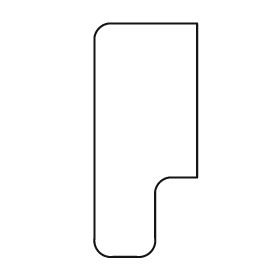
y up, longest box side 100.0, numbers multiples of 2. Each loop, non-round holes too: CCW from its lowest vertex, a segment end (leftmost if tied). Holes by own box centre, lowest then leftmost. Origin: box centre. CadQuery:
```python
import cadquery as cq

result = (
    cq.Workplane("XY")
    .moveTo(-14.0, -50.0)
    .lineTo(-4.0, -50.0)
    .threePointArc((2.0, -48.0), (4.0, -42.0))
    .lineTo(4.0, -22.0)
    .threePointArc((6.0, -18.0), (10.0, -16.0))
    .lineTo(22.0, -16.0)
    .lineTo(22.0, 50.0)
    .lineTo(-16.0, 50.0)
    .threePointArc((-20.0, 48.0), (-22.0, 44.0))
    .lineTo(-22.0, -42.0)
    .threePointArc((-20.0, -48.0), (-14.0, -50.0))
    .close()
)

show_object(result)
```